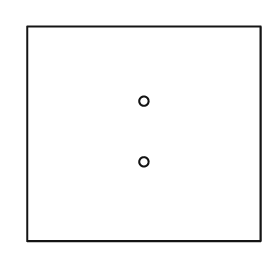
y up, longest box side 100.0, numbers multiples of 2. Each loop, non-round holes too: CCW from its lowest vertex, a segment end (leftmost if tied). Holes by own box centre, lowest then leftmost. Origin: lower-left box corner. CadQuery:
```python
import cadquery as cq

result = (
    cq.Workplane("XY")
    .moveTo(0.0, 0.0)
    .lineTo(100.0, 0.0)
    .lineTo(100.0, 92.0)
    .lineTo(0.0, 92.0)
    .close()
    .moveTo(50.0, 34.0)
    .circle(2.0)
    .moveTo(50.0, 60.0)
    .circle(2.0)
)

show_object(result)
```